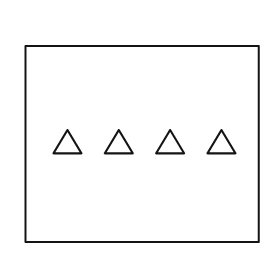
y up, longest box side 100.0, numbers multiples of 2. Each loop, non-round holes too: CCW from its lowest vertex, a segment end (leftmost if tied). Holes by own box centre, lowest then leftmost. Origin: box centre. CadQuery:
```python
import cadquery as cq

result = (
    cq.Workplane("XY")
    .moveTo(-50.0, -42.0)
    .lineTo(50.0, -42.0)
    .lineTo(50.0, 42.0)
    .lineTo(-50.0, 42.0)
    .close()
    .moveTo(-38.0, -4.0)
    .lineTo(-26.0, -4.0)
    .lineTo(-32.0, 6.0)
    .close()
    .moveTo(-16.0, -4.0)
    .lineTo(-4.0, -4.0)
    .lineTo(-10.0, 6.0)
    .close()
    .moveTo(6.0, -4.0)
    .lineTo(18.0, -4.0)
    .lineTo(12.0, 6.0)
    .close()
    .moveTo(28.0, -4.0)
    .lineTo(40.0, -4.0)
    .lineTo(34.0, 6.0)
    .close()
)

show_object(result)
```